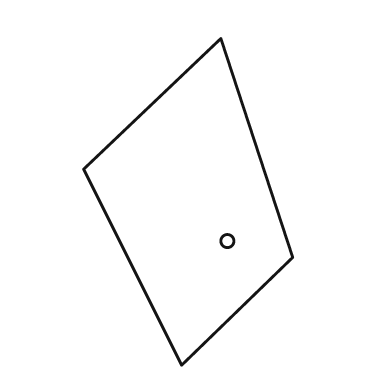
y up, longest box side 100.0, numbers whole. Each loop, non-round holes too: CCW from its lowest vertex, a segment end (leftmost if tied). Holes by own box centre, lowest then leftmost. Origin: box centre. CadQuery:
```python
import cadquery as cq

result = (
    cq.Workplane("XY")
    .moveTo(-2.0, -50.0)
    .lineTo(32.0, -17.0)
    .lineTo(10.0, 50.0)
    .lineTo(-32.0, 10.0)
    .close()
    .moveTo(12.0, -12.0)
    .circle(2.0)
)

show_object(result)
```